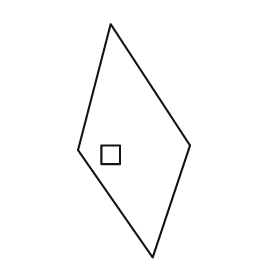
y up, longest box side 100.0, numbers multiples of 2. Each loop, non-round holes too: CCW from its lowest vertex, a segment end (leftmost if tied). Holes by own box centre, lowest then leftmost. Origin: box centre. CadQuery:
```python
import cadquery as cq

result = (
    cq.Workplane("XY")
    .moveTo(8.0, -50.0)
    .lineTo(24.0, -2.0)
    .lineTo(-10.0, 50.0)
    .lineTo(-24.0, -4.0)
    .close()
    .moveTo(-14.0, -10.0)
    .lineTo(-6.0, -10.0)
    .lineTo(-6.0, -2.0)
    .lineTo(-14.0, -2.0)
    .close()
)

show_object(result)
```